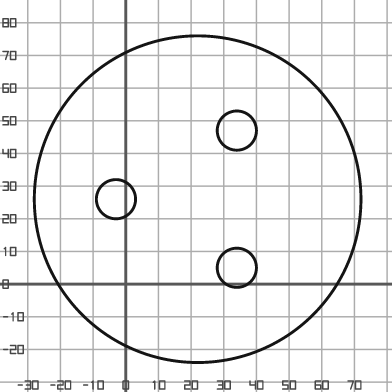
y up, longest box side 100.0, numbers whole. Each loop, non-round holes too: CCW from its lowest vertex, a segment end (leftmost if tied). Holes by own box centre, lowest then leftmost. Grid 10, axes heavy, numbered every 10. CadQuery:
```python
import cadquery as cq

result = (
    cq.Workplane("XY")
    .moveTo(22.0, 26.0)
    .circle(50.0)
    .moveTo(34.0, 5.0)
    .circle(6.0)
    .moveTo(-3.0, 26.0)
    .circle(6.0)
    .moveTo(34.0, 47.0)
    .circle(6.0)
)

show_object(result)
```